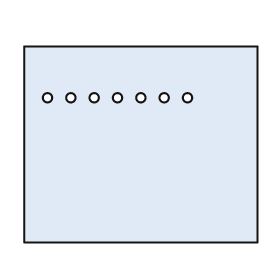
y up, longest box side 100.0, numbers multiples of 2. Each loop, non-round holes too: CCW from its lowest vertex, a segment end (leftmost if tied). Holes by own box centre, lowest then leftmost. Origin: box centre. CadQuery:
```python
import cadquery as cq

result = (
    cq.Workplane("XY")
    .moveTo(-50.0, -42.0)
    .lineTo(50.0, -42.0)
    .lineTo(50.0, 42.0)
    .lineTo(-50.0, 42.0)
    .close()
    .moveTo(-40.0, 20.0)
    .circle(2.0)
    .moveTo(-30.0, 20.0)
    .circle(2.0)
    .moveTo(-20.0, 20.0)
    .circle(2.0)
    .moveTo(-10.0, 20.0)
    .circle(2.0)
    .moveTo(0.0, 20.0)
    .circle(2.0)
    .moveTo(10.0, 20.0)
    .circle(2.0)
    .moveTo(20.0, 20.0)
    .circle(2.0)
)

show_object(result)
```